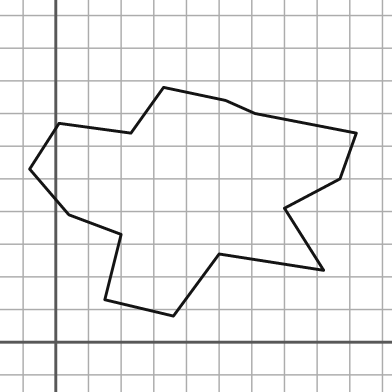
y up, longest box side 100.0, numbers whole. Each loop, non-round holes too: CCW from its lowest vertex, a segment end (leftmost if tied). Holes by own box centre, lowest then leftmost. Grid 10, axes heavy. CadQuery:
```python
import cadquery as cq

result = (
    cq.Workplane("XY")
    .moveTo(36.0, 8.0)
    .lineTo(50.0, 27.0)
    .lineTo(82.0, 22.0)
    .lineTo(70.0, 41.0)
    .lineTo(87.0, 50.0)
    .lineTo(92.0, 64.0)
    .lineTo(61.0, 70.0)
    .lineTo(52.0, 74.0)
    .lineTo(33.0, 78.0)
    .lineTo(23.0, 64.0)
    .lineTo(1.0, 67.0)
    .lineTo(-8.0, 53.0)
    .lineTo(4.0, 39.0)
    .lineTo(20.0, 33.0)
    .lineTo(15.0, 13.0)
    .close()
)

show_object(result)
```